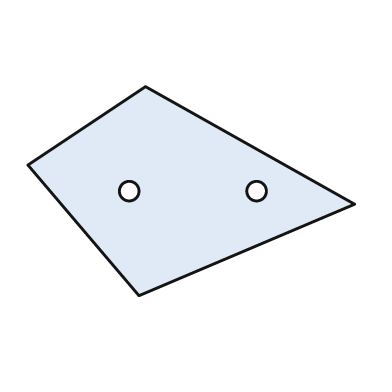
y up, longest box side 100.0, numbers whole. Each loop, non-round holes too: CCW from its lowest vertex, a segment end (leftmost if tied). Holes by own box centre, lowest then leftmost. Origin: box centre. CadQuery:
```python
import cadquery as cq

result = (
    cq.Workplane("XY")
    .moveTo(-16.0, -32.0)
    .lineTo(50.0, -4.0)
    .lineTo(-14.0, 32.0)
    .lineTo(-50.0, 8.0)
    .close()
    .moveTo(-19.0, 0.0)
    .circle(3.0)
    .moveTo(20.0, 0.0)
    .circle(3.0)
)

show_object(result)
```